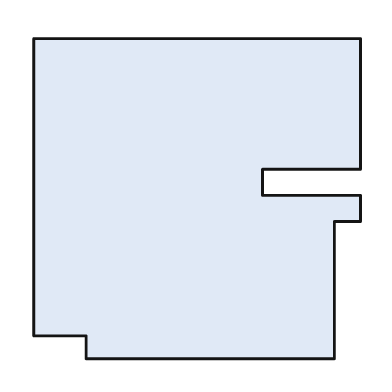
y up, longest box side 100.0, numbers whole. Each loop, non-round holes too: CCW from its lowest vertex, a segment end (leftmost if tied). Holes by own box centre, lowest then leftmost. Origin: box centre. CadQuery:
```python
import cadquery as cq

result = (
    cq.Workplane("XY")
    .moveTo(-34.0, -49.0)
    .lineTo(42.0, -49.0)
    .lineTo(42.0, -7.0)
    .lineTo(50.0, -7.0)
    .lineTo(50.0, 1.0)
    .lineTo(20.0, 1.0)
    .lineTo(20.0, 9.0)
    .lineTo(50.0, 9.0)
    .lineTo(50.0, 49.0)
    .lineTo(-50.0, 49.0)
    .lineTo(-50.0, -42.0)
    .lineTo(-34.0, -42.0)
    .close()
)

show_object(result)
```